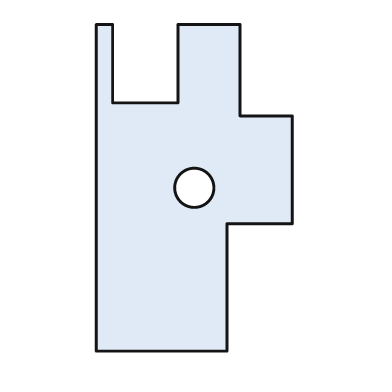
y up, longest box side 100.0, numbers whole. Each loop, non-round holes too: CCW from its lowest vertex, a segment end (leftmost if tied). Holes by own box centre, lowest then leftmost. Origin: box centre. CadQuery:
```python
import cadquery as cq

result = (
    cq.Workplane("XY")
    .moveTo(-30.0, -50.0)
    .lineTo(10.0, -50.0)
    .lineTo(10.0, -11.0)
    .lineTo(30.0, -11.0)
    .lineTo(30.0, 22.0)
    .lineTo(14.0, 22.0)
    .lineTo(14.0, 50.0)
    .lineTo(-5.0, 50.0)
    .lineTo(-5.0, 26.0)
    .lineTo(-25.0, 26.0)
    .lineTo(-25.0, 50.0)
    .lineTo(-30.0, 50.0)
    .close()
    .moveTo(0.0, 0.0)
    .circle(6.0)
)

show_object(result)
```